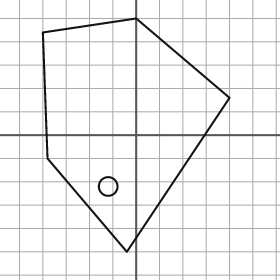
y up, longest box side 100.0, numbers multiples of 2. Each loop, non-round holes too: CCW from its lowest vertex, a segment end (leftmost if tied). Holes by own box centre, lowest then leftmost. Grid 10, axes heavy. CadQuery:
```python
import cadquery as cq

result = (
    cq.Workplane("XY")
    .moveTo(-4.0, -50.0)
    .lineTo(40.0, 16.0)
    .lineTo(0.0, 50.0)
    .lineTo(-40.0, 44.0)
    .lineTo(-38.0, -10.0)
    .close()
    .moveTo(-12.0, -22.0)
    .circle(4.0)
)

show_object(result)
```